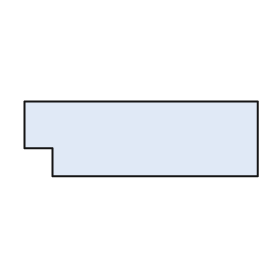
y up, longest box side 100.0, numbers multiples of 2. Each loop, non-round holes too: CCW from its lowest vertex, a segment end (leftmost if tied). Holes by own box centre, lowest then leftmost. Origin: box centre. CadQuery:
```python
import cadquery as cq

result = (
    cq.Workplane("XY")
    .moveTo(-38.0, -16.0)
    .lineTo(50.0, -16.0)
    .lineTo(50.0, 16.0)
    .lineTo(-50.0, 16.0)
    .lineTo(-50.0, -4.0)
    .lineTo(-38.0, -4.0)
    .close()
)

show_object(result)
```